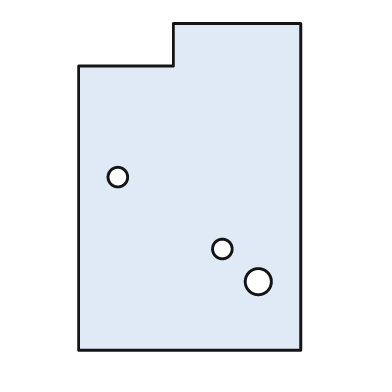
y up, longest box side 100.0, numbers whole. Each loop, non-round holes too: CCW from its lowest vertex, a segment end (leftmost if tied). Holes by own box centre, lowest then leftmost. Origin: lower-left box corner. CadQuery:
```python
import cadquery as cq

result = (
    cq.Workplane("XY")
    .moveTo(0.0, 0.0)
    .lineTo(68.0, 0.0)
    .lineTo(68.0, 100.0)
    .lineTo(29.0, 100.0)
    .lineTo(29.0, 87.0)
    .lineTo(0.0, 87.0)
    .close()
    .moveTo(55.0, 21.0)
    .circle(4.0)
    .moveTo(44.0, 31.0)
    .circle(3.0)
    .moveTo(12.0, 53.0)
    .circle(3.0)
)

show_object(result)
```